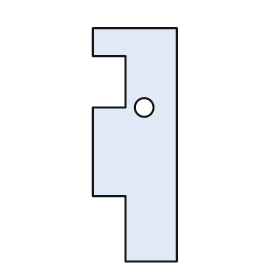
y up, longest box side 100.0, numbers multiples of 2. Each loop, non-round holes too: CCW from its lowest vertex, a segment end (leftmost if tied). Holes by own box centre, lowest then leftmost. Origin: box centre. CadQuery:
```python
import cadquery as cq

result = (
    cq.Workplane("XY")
    .moveTo(-4.0, -50.0)
    .lineTo(18.0, -50.0)
    .lineTo(18.0, 50.0)
    .lineTo(-18.0, 50.0)
    .lineTo(-18.0, 38.0)
    .lineTo(-4.0, 38.0)
    .lineTo(-4.0, 16.0)
    .lineTo(-18.0, 16.0)
    .lineTo(-18.0, -22.0)
    .lineTo(-4.0, -22.0)
    .close()
    .moveTo(4.0, 16.0)
    .circle(4.0)
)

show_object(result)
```